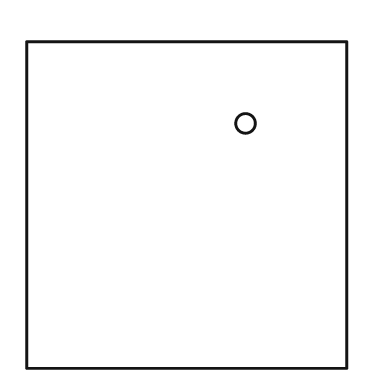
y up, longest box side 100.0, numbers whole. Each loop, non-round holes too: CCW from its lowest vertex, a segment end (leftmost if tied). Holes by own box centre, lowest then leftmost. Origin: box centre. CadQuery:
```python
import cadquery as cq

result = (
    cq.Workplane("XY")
    .moveTo(-49.0, -50.0)
    .lineTo(49.0, -50.0)
    .lineTo(49.0, 50.0)
    .lineTo(-49.0, 50.0)
    .close()
    .moveTo(18.0, 25.0)
    .circle(3.0)
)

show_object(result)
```